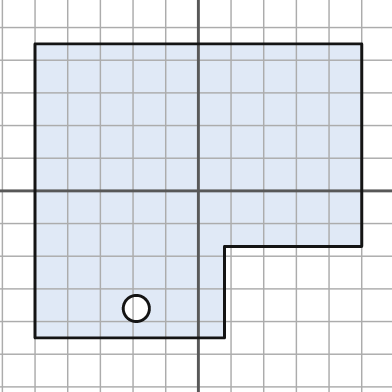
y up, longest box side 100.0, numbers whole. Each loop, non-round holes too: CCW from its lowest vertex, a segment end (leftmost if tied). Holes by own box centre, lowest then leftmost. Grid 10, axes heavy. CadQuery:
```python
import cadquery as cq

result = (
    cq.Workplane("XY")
    .moveTo(-50.0, -45.0)
    .lineTo(8.0, -45.0)
    .lineTo(8.0, -17.0)
    .lineTo(50.0, -17.0)
    .lineTo(50.0, 45.0)
    .lineTo(-50.0, 45.0)
    .close()
    .moveTo(-19.0, -36.0)
    .circle(4.0)
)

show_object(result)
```